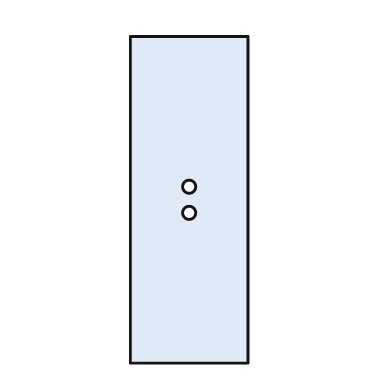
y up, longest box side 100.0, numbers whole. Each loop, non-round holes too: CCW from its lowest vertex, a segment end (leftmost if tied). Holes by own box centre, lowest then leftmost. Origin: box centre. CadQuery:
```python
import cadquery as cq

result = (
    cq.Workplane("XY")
    .moveTo(-18.0, -50.0)
    .lineTo(18.0, -50.0)
    .lineTo(18.0, 50.0)
    .lineTo(-18.0, 50.0)
    .close()
    .moveTo(0.0, -4.0)
    .circle(2.0)
    .moveTo(0.0, 4.0)
    .circle(2.0)
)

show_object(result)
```